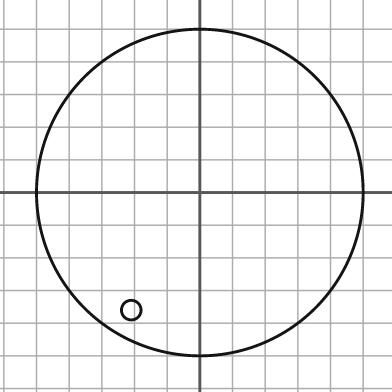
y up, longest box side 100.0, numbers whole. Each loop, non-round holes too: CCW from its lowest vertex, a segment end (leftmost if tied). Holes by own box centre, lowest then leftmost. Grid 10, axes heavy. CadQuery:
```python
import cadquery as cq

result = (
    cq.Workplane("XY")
    .moveTo(0.0, 0.0)
    .circle(50.0)
    .moveTo(-21.0, -36.0)
    .circle(3.0)
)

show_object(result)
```